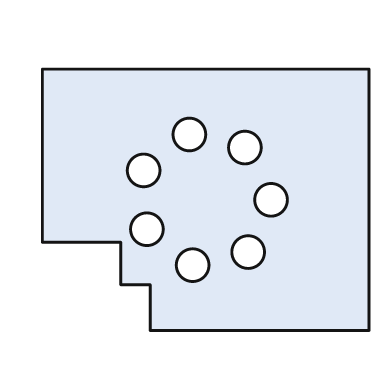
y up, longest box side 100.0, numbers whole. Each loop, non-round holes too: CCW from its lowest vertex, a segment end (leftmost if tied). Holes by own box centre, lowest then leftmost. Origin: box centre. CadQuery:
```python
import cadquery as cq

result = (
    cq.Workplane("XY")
    .moveTo(-17.0, -40.0)
    .lineTo(50.0, -40.0)
    .lineTo(50.0, 40.0)
    .lineTo(-50.0, 40.0)
    .lineTo(-50.0, -13.0)
    .lineTo(-26.0, -13.0)
    .lineTo(-26.0, -26.0)
    .lineTo(-17.0, -26.0)
    .close()
    .moveTo(-4.0, -20.0)
    .circle(5.0)
    .moveTo(13.0, -16.0)
    .circle(5.0)
    .moveTo(-18.0, -9.0)
    .circle(5.0)
    .moveTo(20.0, 0.0)
    .circle(5.0)
    .moveTo(-19.0, 9.0)
    .circle(5.0)
    .moveTo(12.0, 16.0)
    .circle(5.0)
    .moveTo(-5.0, 20.0)
    .circle(5.0)
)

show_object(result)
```